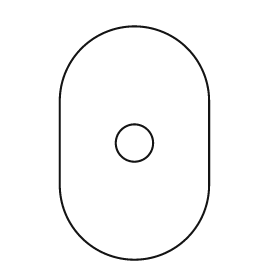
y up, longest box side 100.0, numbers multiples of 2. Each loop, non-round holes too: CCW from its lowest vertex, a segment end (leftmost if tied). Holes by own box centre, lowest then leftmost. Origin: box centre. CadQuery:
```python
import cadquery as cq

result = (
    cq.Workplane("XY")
    .moveTo(-32.0, -18.0)
    .threePointArc((0.0, -50.0), (32.0, -18.0))
    .lineTo(32.0, 18.0)
    .threePointArc((0.0, 50.0), (-32.0, 18.0))
    .close()
    .moveTo(0.0, 0.0)
    .circle(8.0)
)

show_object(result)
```